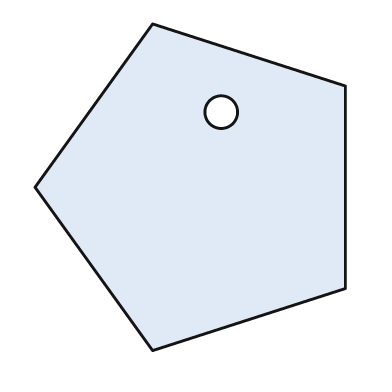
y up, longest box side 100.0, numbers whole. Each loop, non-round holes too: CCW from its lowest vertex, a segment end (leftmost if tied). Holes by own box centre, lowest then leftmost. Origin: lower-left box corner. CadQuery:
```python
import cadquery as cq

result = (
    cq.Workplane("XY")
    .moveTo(36.0, 0.0)
    .lineTo(95.0, 19.0)
    .lineTo(95.0, 81.0)
    .lineTo(36.0, 100.0)
    .lineTo(0.0, 50.0)
    .close()
    .moveTo(57.0, 73.0)
    .circle(5.0)
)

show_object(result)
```